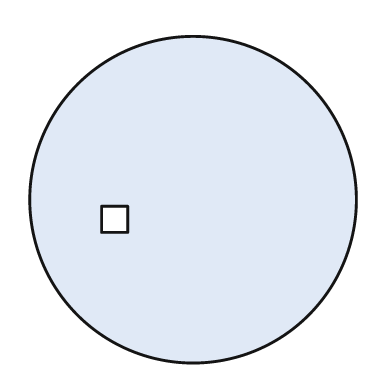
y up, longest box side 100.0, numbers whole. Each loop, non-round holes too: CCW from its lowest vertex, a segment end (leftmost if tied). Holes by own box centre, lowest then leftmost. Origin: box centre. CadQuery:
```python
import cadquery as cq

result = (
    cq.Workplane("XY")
    .moveTo(0.0, 0.0)
    .circle(50.0)
    .moveTo(-28.0, -10.0)
    .lineTo(-20.0, -10.0)
    .lineTo(-20.0, -2.0)
    .lineTo(-28.0, -2.0)
    .close()
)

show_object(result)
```